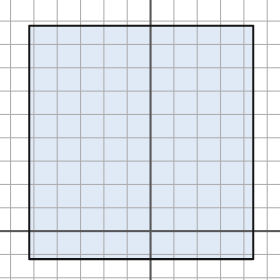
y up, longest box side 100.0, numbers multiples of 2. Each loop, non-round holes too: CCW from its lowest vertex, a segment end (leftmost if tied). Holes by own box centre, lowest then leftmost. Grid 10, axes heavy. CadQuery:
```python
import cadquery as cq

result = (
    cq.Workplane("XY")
    .moveTo(-52.0, -12.0)
    .lineTo(44.0, -12.0)
    .lineTo(44.0, 88.0)
    .lineTo(-52.0, 88.0)
    .close()
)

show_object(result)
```